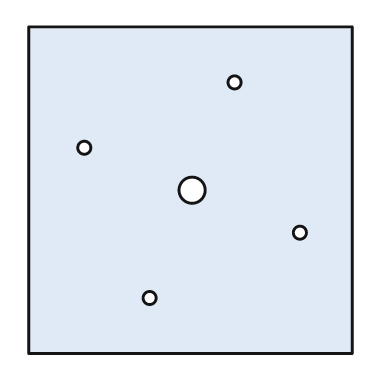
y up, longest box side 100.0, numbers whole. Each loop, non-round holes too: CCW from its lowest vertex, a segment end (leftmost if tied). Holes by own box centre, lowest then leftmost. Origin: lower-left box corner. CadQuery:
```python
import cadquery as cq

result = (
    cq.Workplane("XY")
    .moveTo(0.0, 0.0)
    .lineTo(99.0, 0.0)
    .lineTo(99.0, 100.0)
    .lineTo(0.0, 100.0)
    .close()
    .moveTo(37.0, 17.0)
    .circle(2.0)
    .moveTo(83.0, 37.0)
    .circle(2.0)
    .moveTo(50.0, 50.0)
    .circle(4.0)
    .moveTo(17.0, 63.0)
    .circle(2.0)
    .moveTo(63.0, 83.0)
    .circle(2.0)
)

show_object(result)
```